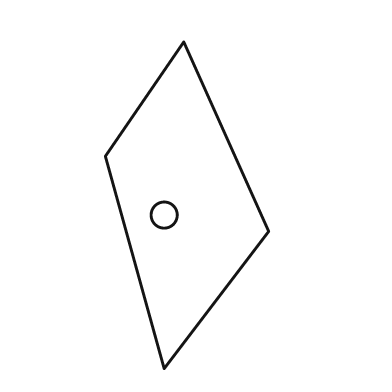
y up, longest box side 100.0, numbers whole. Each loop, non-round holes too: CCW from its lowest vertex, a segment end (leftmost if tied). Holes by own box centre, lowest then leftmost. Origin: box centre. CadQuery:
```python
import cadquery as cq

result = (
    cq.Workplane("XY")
    .moveTo(-7.0, -50.0)
    .lineTo(25.0, -8.0)
    .lineTo(-1.0, 50.0)
    .lineTo(-25.0, 15.0)
    .close()
    .moveTo(-7.0, -3.0)
    .circle(4.0)
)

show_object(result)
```